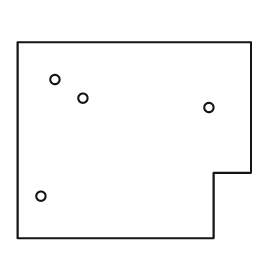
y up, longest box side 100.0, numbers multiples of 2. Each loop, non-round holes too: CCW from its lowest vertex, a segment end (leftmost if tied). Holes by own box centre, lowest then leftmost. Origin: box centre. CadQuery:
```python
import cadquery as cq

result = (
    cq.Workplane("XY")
    .moveTo(-50.0, -42.0)
    .lineTo(34.0, -42.0)
    .lineTo(34.0, -14.0)
    .lineTo(50.0, -14.0)
    .lineTo(50.0, 42.0)
    .lineTo(-50.0, 42.0)
    .close()
    .moveTo(-40.0, -24.0)
    .circle(2.0)
    .moveTo(32.0, 14.0)
    .circle(2.0)
    .moveTo(-22.0, 18.0)
    .circle(2.0)
    .moveTo(-34.0, 26.0)
    .circle(2.0)
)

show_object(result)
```